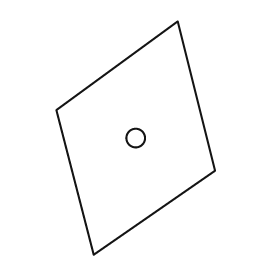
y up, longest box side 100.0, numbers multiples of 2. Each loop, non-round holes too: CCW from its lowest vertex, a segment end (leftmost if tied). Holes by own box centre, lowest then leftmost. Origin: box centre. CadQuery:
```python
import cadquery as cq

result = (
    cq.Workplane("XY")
    .moveTo(-18.0, -50.0)
    .lineTo(34.0, -14.0)
    .lineTo(18.0, 50.0)
    .lineTo(-34.0, 12.0)
    .close()
    .moveTo(0.0, 0.0)
    .circle(4.0)
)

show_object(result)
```